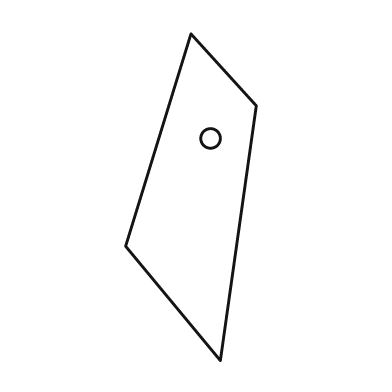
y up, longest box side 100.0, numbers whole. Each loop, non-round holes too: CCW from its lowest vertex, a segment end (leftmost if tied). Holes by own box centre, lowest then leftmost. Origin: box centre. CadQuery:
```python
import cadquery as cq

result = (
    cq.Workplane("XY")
    .moveTo(9.0, -50.0)
    .lineTo(20.0, 28.0)
    .lineTo(0.0, 50.0)
    .lineTo(-20.0, -15.0)
    .close()
    .moveTo(6.0, 18.0)
    .circle(3.0)
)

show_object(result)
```